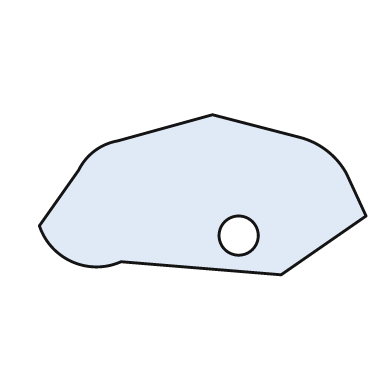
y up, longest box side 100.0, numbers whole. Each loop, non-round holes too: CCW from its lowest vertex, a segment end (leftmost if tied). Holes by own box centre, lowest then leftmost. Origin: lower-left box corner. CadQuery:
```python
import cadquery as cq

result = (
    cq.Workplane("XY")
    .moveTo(74.0, 0.0)
    .lineTo(100.0, 18.0)
    .lineTo(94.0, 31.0)
    .threePointArc((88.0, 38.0), (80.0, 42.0))
    .lineTo(53.0, 49.0)
    .lineTo(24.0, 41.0)
    .threePointArc((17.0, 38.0), (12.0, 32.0))
    .lineTo(0.0, 15.0)
    .threePointArc((10.0, 4.0), (25.0, 4.0))
    .close()
    .moveTo(61.0, 12.0)
    .circle(6.0)
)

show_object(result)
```